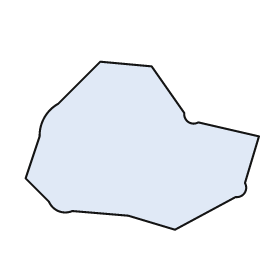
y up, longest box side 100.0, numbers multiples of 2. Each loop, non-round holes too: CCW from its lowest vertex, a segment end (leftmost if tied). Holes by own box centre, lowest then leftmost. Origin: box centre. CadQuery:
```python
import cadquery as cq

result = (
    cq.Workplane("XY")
    .moveTo(14.0, -36.0)
    .lineTo(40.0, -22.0)
    .threePointArc((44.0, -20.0), (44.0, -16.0))
    .lineTo(50.0, 4.0)
    .lineTo(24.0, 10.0)
    .threePointArc((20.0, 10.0), (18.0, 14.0))
    .lineTo(4.0, 34.0)
    .lineTo(-18.0, 36.0)
    .lineTo(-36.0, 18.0)
    .threePointArc((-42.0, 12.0), (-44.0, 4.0))
    .lineTo(-50.0, -14.0)
    .lineTo(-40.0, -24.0)
    .threePointArc((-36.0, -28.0), (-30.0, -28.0))
    .lineTo(-6.0, -30.0)
    .close()
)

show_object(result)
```